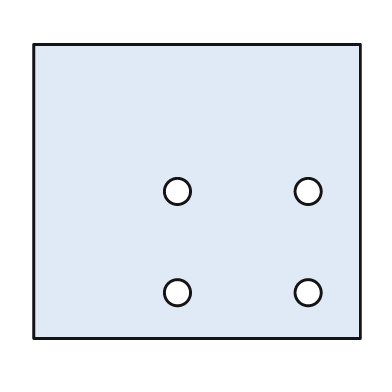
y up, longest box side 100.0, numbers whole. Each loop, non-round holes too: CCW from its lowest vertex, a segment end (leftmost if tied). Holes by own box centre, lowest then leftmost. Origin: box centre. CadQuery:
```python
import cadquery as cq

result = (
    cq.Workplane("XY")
    .moveTo(-50.0, -45.0)
    .lineTo(50.0, -45.0)
    .lineTo(50.0, 45.0)
    .lineTo(-50.0, 45.0)
    .close()
    .moveTo(-6.0, -31.0)
    .circle(4.0)
    .moveTo(34.0, -31.0)
    .circle(4.0)
    .moveTo(-6.0, 0.0)
    .circle(4.0)
    .moveTo(34.0, 0.0)
    .circle(4.0)
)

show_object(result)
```